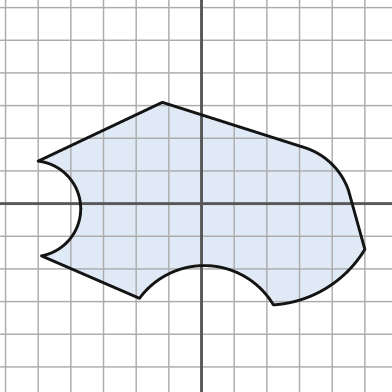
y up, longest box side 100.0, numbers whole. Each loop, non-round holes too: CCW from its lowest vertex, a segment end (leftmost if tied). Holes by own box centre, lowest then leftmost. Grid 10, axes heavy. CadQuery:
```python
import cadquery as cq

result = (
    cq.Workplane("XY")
    .moveTo(22.0, -31.0)
    .threePointArc((38.0, -26.0), (50.0, -14.0))
    .lineTo(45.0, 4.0)
    .threePointArc((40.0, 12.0), (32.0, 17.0))
    .lineTo(-12.0, 31.0)
    .lineTo(-50.0, 13.0)
    .threePointArc((-37.0, -1.0), (-49.0, -16.0))
    .lineTo(-19.0, -29.0)
    .threePointArc((2.0, -19.0), (22.0, -31.0))
    .close()
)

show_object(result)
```